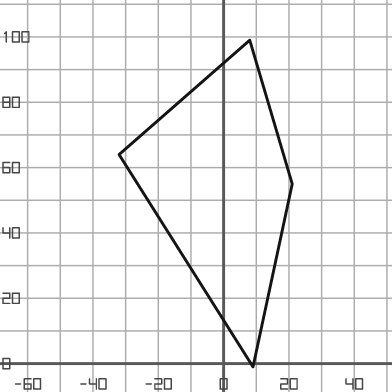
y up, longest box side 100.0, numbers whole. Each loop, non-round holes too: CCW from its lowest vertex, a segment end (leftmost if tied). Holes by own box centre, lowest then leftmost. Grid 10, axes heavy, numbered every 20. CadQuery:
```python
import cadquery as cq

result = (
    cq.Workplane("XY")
    .moveTo(9.0, -1.0)
    .lineTo(21.0, 55.0)
    .lineTo(8.0, 99.0)
    .lineTo(-32.0, 64.0)
    .close()
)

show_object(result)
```